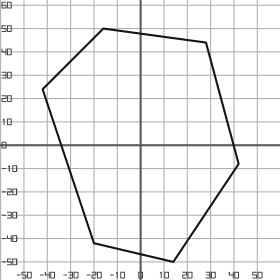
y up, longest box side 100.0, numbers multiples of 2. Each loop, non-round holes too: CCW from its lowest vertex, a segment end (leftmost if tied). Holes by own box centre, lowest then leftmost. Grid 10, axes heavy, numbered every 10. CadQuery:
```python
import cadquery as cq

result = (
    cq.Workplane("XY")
    .moveTo(14.0, -50.0)
    .lineTo(42.0, -8.0)
    .lineTo(28.0, 44.0)
    .lineTo(-16.0, 50.0)
    .lineTo(-42.0, 24.0)
    .lineTo(-20.0, -42.0)
    .close()
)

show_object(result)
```